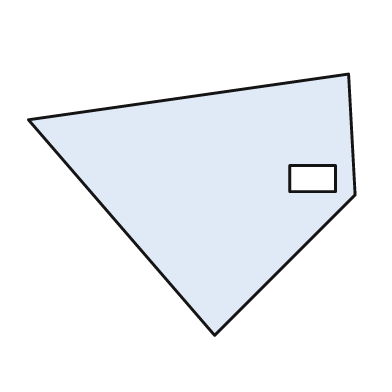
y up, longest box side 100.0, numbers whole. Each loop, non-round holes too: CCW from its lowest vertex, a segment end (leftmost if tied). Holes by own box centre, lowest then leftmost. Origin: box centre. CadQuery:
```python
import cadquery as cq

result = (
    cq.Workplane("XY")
    .moveTo(7.0, -40.0)
    .lineTo(50.0, 3.0)
    .lineTo(48.0, 40.0)
    .lineTo(-50.0, 26.0)
    .close()
    .moveTo(30.0, 4.0)
    .lineTo(44.0, 4.0)
    .lineTo(44.0, 12.0)
    .lineTo(30.0, 12.0)
    .close()
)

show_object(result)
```